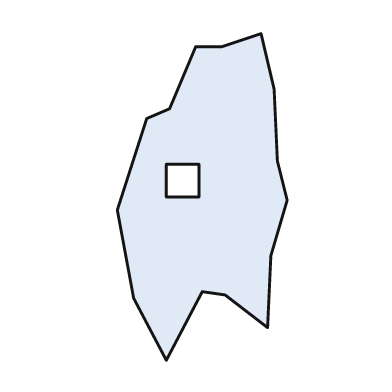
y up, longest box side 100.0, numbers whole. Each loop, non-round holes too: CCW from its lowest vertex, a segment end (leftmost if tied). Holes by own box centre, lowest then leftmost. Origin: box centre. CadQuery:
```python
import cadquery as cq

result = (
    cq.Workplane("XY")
    .moveTo(-11.0, -50.0)
    .lineTo(0.0, -29.0)
    .lineTo(7.0, -30.0)
    .lineTo(20.0, -40.0)
    .lineTo(21.0, -18.0)
    .lineTo(26.0, -1.0)
    .lineTo(23.0, 11.0)
    .lineTo(22.0, 33.0)
    .lineTo(18.0, 50.0)
    .lineTo(6.0, 46.0)
    .lineTo(-2.0, 46.0)
    .lineTo(-10.0, 27.0)
    .lineTo(-17.0, 24.0)
    .lineTo(-26.0, -4.0)
    .lineTo(-21.0, -31.0)
    .close()
    .moveTo(-11.0, 0.0)
    .lineTo(-1.0, 0.0)
    .lineTo(-1.0, 10.0)
    .lineTo(-11.0, 10.0)
    .close()
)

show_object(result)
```